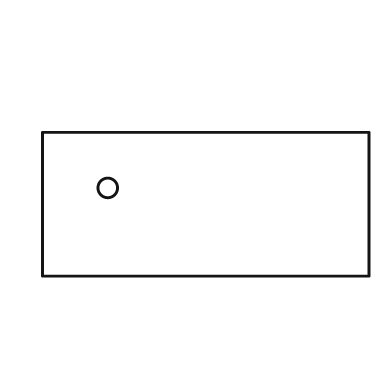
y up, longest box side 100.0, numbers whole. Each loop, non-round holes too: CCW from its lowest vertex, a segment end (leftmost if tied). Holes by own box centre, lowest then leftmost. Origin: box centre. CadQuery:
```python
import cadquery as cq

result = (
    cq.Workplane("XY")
    .moveTo(-50.0, -22.0)
    .lineTo(50.0, -22.0)
    .lineTo(50.0, 22.0)
    .lineTo(-50.0, 22.0)
    .close()
    .moveTo(-30.0, 5.0)
    .circle(3.0)
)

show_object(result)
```